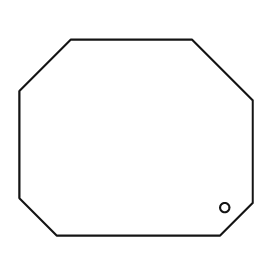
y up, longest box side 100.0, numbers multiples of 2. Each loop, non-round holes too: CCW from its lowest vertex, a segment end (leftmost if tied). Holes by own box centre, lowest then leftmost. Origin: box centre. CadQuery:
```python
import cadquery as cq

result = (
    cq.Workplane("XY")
    .moveTo(-34.0, -42.0)
    .lineTo(36.0, -42.0)
    .lineTo(50.0, -28.0)
    .lineTo(50.0, 16.0)
    .lineTo(24.0, 42.0)
    .lineTo(-28.0, 42.0)
    .lineTo(-50.0, 20.0)
    .lineTo(-50.0, -26.0)
    .close()
    .moveTo(38.0, -30.0)
    .circle(2.0)
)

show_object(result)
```